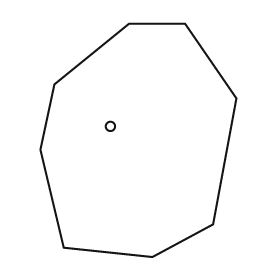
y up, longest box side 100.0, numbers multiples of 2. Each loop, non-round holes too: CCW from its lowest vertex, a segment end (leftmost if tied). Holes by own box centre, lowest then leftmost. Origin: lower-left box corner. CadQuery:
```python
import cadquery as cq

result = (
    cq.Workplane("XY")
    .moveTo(48.0, 0.0)
    .lineTo(74.0, 14.0)
    .lineTo(84.0, 68.0)
    .lineTo(62.0, 100.0)
    .lineTo(38.0, 100.0)
    .lineTo(6.0, 74.0)
    .lineTo(0.0, 46.0)
    .lineTo(10.0, 4.0)
    .close()
    .moveTo(30.0, 56.0)
    .circle(2.0)
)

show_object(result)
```